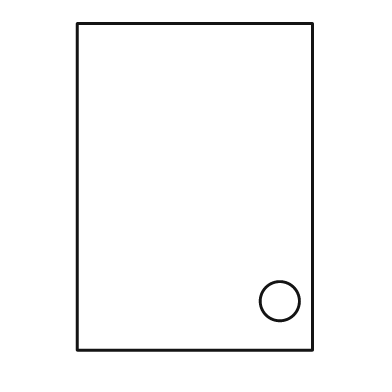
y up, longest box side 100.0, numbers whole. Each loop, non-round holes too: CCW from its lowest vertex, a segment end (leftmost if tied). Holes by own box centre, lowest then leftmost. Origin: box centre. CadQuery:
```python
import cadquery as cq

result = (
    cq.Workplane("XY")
    .moveTo(-36.0, -50.0)
    .lineTo(36.0, -50.0)
    .lineTo(36.0, 50.0)
    .lineTo(-36.0, 50.0)
    .close()
    .moveTo(26.0, -35.0)
    .circle(6.0)
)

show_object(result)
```